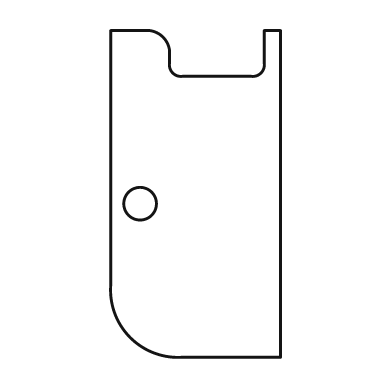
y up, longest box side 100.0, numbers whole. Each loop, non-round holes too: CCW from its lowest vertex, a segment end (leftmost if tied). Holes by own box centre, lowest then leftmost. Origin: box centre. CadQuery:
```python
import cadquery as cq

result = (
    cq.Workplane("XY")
    .moveTo(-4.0, -50.0)
    .lineTo(26.0, -50.0)
    .lineTo(26.0, 50.0)
    .lineTo(21.0, 50.0)
    .lineTo(21.0, 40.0)
    .threePointArc((20.0, 37.0), (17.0, 36.0))
    .lineTo(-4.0, 36.0)
    .threePointArc((-7.0, 37.0), (-8.0, 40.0))
    .lineTo(-8.0, 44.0)
    .threePointArc((-10.0, 48.0), (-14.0, 50.0))
    .lineTo(-26.0, 50.0)
    .lineTo(-26.0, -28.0)
    .threePointArc((-20.0, -44.0), (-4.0, -50.0))
    .close()
    .moveTo(-17.0, -3.0)
    .circle(5.0)
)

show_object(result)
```